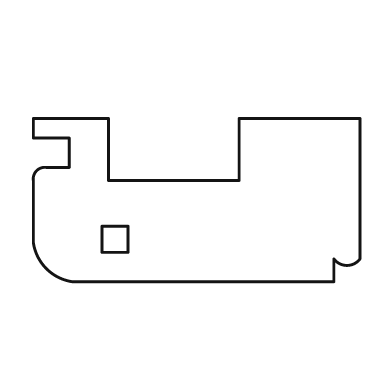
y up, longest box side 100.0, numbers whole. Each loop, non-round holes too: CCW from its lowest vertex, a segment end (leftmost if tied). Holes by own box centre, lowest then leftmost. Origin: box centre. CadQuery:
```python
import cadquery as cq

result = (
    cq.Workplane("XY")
    .moveTo(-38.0, -25.0)
    .lineTo(42.0, -25.0)
    .lineTo(42.0, -18.0)
    .threePointArc((46.0, -20.0), (50.0, -18.0))
    .lineTo(50.0, 25.0)
    .lineTo(13.0, 25.0)
    .lineTo(13.0, 6.0)
    .lineTo(-27.0, 6.0)
    .lineTo(-27.0, 25.0)
    .lineTo(-50.0, 25.0)
    .lineTo(-50.0, 19.0)
    .lineTo(-39.0, 19.0)
    .lineTo(-39.0, 10.0)
    .lineTo(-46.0, 10.0)
    .threePointArc((-49.0, 9.0), (-50.0, 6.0))
    .lineTo(-50.0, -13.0)
    .threePointArc((-46.0, -21.0), (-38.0, -25.0))
    .close()
    .moveTo(-29.0, -16.0)
    .lineTo(-21.0, -16.0)
    .lineTo(-21.0, -8.0)
    .lineTo(-29.0, -8.0)
    .close()
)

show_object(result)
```